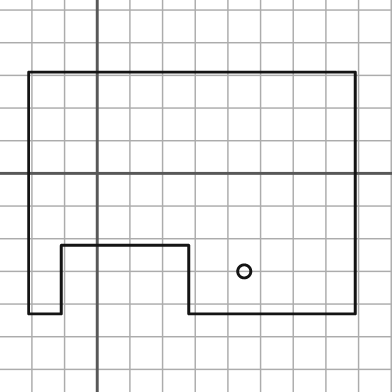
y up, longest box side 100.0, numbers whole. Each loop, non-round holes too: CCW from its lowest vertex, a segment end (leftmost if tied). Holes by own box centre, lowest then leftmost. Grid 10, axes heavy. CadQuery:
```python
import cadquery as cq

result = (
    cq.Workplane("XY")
    .moveTo(-21.0, -43.0)
    .lineTo(-11.0, -43.0)
    .lineTo(-11.0, -22.0)
    .lineTo(28.0, -22.0)
    .lineTo(28.0, -43.0)
    .lineTo(79.0, -43.0)
    .lineTo(79.0, 31.0)
    .lineTo(-21.0, 31.0)
    .close()
    .moveTo(45.0, -30.0)
    .circle(2.0)
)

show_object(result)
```